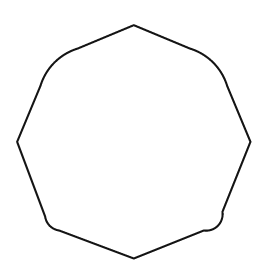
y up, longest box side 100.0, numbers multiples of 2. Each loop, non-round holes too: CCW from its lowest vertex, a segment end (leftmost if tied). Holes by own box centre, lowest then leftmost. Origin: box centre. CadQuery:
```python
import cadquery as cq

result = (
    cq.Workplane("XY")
    .moveTo(0.0, -50.0)
    .lineTo(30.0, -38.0)
    .threePointArc((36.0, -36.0), (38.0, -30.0))
    .lineTo(50.0, 0.0)
    .lineTo(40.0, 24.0)
    .threePointArc((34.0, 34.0), (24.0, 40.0))
    .lineTo(0.0, 50.0)
    .lineTo(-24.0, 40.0)
    .threePointArc((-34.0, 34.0), (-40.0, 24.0))
    .lineTo(-50.0, 0.0)
    .lineTo(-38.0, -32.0)
    .threePointArc((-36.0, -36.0), (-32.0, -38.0))
    .close()
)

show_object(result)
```